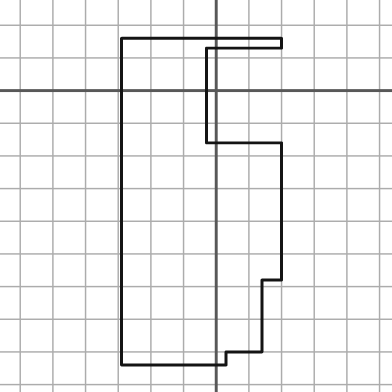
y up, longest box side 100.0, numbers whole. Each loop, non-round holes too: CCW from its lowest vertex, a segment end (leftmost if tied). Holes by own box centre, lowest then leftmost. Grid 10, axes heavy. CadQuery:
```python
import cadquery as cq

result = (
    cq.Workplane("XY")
    .moveTo(-29.0, -84.0)
    .lineTo(3.0, -84.0)
    .lineTo(3.0, -80.0)
    .lineTo(14.0, -80.0)
    .lineTo(14.0, -58.0)
    .lineTo(20.0, -58.0)
    .lineTo(20.0, -16.0)
    .lineTo(-3.0, -16.0)
    .lineTo(-3.0, 13.0)
    .lineTo(20.0, 13.0)
    .lineTo(20.0, 16.0)
    .lineTo(-29.0, 16.0)
    .close()
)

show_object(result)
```